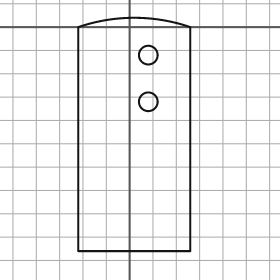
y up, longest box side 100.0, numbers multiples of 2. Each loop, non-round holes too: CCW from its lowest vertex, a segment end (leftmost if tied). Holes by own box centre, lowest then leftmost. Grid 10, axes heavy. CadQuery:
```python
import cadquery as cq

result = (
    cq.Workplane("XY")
    .moveTo(-22.0, -96.0)
    .lineTo(26.0, -96.0)
    .lineTo(26.0, 0.0)
    .threePointArc((2.0, 4.0), (-22.0, 0.0))
    .close()
    .moveTo(8.0, -32.0)
    .circle(4.0)
    .moveTo(8.0, -12.0)
    .circle(4.0)
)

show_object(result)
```